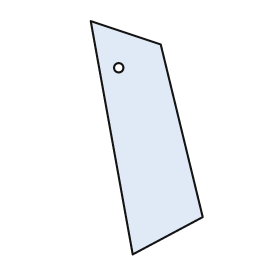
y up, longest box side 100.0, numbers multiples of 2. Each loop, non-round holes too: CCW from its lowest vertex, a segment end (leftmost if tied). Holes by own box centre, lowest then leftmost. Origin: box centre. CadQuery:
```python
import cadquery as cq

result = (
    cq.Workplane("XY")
    .moveTo(-6.0, -50.0)
    .lineTo(24.0, -34.0)
    .lineTo(6.0, 40.0)
    .lineTo(-24.0, 50.0)
    .close()
    .moveTo(-12.0, 30.0)
    .circle(2.0)
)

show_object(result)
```